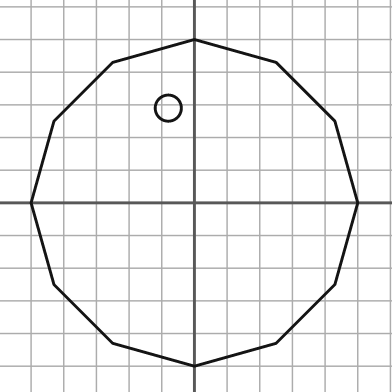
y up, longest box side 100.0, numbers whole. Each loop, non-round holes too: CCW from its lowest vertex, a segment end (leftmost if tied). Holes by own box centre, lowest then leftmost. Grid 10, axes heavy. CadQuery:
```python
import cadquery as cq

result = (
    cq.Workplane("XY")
    .moveTo(0.0, -50.0)
    .lineTo(25.0, -43.0)
    .lineTo(43.0, -25.0)
    .lineTo(50.0, 0.0)
    .lineTo(43.0, 25.0)
    .lineTo(25.0, 43.0)
    .lineTo(0.0, 50.0)
    .lineTo(-25.0, 43.0)
    .lineTo(-43.0, 25.0)
    .lineTo(-50.0, 0.0)
    .lineTo(-43.0, -25.0)
    .lineTo(-25.0, -43.0)
    .close()
    .moveTo(-8.0, 29.0)
    .circle(4.0)
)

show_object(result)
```